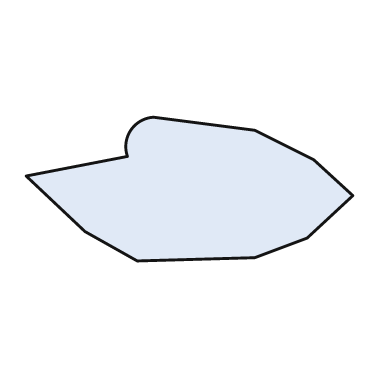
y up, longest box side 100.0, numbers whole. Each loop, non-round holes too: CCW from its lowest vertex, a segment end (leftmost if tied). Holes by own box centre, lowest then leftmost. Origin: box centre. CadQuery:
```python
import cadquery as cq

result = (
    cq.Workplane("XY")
    .moveTo(-16.0, -22.0)
    .lineTo(20.0, -21.0)
    .lineTo(36.0, -15.0)
    .lineTo(50.0, -2.0)
    .lineTo(38.0, 9.0)
    .lineTo(20.0, 18.0)
    .lineTo(-11.0, 22.0)
    .threePointArc((-18.0, 18.0), (-19.0, 10.0))
    .lineTo(-50.0, 4.0)
    .lineTo(-32.0, -13.0)
    .close()
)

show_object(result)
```